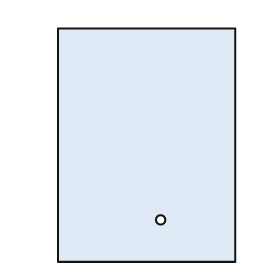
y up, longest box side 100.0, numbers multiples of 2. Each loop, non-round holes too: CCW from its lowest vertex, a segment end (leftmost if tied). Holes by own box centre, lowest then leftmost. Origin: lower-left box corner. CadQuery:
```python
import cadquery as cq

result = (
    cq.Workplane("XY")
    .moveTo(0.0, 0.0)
    .lineTo(76.0, 0.0)
    .lineTo(76.0, 100.0)
    .lineTo(0.0, 100.0)
    .close()
    .moveTo(44.0, 18.0)
    .circle(2.0)
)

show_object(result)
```